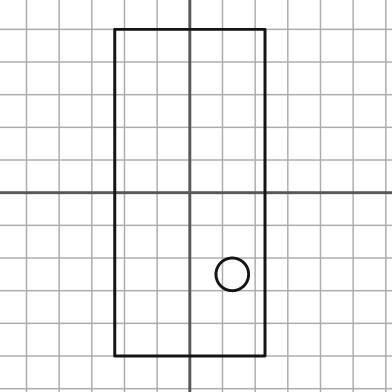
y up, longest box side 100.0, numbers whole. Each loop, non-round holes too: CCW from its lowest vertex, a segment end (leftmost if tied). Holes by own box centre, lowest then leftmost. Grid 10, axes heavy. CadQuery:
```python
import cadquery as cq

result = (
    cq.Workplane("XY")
    .moveTo(-23.0, -50.0)
    .lineTo(23.0, -50.0)
    .lineTo(23.0, 50.0)
    .lineTo(-23.0, 50.0)
    .close()
    .moveTo(13.0, -25.0)
    .circle(5.0)
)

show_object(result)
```